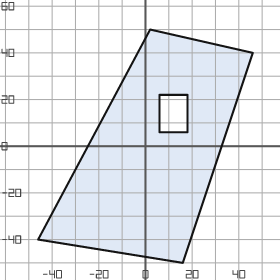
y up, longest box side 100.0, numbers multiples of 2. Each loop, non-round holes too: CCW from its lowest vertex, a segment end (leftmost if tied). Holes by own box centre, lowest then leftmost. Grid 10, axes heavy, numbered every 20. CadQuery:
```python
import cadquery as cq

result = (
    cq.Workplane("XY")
    .moveTo(16.0, -50.0)
    .lineTo(46.0, 40.0)
    .lineTo(2.0, 50.0)
    .lineTo(-46.0, -40.0)
    .close()
    .moveTo(6.0, 6.0)
    .lineTo(18.0, 6.0)
    .lineTo(18.0, 22.0)
    .lineTo(6.0, 22.0)
    .close()
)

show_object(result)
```